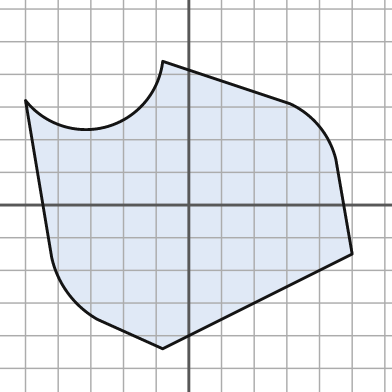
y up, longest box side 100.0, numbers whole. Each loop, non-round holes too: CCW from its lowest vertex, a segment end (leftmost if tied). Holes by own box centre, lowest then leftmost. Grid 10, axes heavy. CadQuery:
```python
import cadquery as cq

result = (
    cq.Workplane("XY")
    .moveTo(-8.0, -44.0)
    .lineTo(50.0, -15.0)
    .lineTo(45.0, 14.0)
    .threePointArc((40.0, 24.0), (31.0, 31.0))
    .lineTo(-8.0, 44.0)
    .threePointArc((-25.0, 24.0), (-50.0, 32.0))
    .lineTo(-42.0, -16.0)
    .threePointArc((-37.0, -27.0), (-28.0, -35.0))
    .close()
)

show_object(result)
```